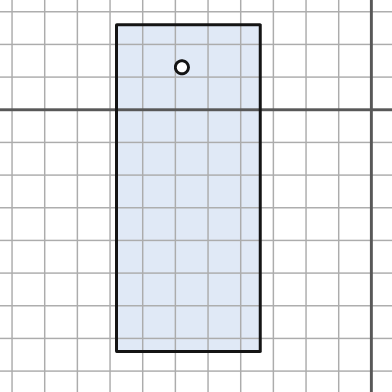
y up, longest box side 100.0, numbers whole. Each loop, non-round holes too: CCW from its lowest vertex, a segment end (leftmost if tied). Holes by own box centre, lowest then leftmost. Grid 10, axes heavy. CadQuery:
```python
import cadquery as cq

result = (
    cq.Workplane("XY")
    .moveTo(-78.0, -74.0)
    .lineTo(-34.0, -74.0)
    .lineTo(-34.0, 26.0)
    .lineTo(-78.0, 26.0)
    .close()
    .moveTo(-58.0, 13.0)
    .circle(2.0)
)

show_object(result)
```